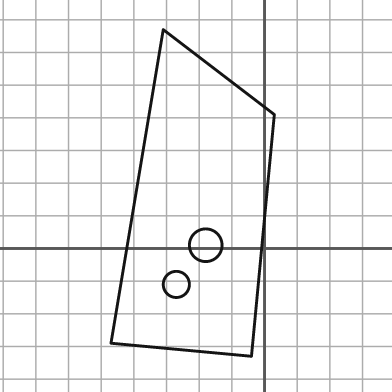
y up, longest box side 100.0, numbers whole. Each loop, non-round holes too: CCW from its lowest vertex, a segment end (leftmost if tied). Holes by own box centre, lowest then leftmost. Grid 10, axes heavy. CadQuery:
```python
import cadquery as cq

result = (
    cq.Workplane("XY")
    .moveTo(-4.0, -33.0)
    .lineTo(3.0, 41.0)
    .lineTo(-31.0, 67.0)
    .lineTo(-47.0, -29.0)
    .close()
    .moveTo(-27.0, -11.0)
    .circle(4.0)
    .moveTo(-18.0, 1.0)
    .circle(5.0)
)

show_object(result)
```